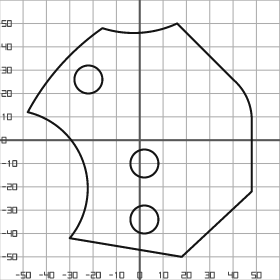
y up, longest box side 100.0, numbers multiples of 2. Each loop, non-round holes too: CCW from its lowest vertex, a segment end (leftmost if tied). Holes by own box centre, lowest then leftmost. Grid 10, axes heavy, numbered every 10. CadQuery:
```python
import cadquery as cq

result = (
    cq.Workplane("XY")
    .moveTo(18.0, -50.0)
    .lineTo(48.0, -22.0)
    .lineTo(48.0, 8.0)
    .threePointArc((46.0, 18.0), (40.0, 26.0))
    .lineTo(16.0, 50.0)
    .threePointArc((0.0, 46.0), (-16.0, 48.0))
    .threePointArc((-34.0, 32.0), (-48.0, 12.0))
    .threePointArc((-24.0, -10.0), (-30.0, -42.0))
    .close()
    .moveTo(2.0, -34.0)
    .circle(6.0)
    .moveTo(2.0, -10.0)
    .circle(6.0)
    .moveTo(-22.0, 26.0)
    .circle(6.0)
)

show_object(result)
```